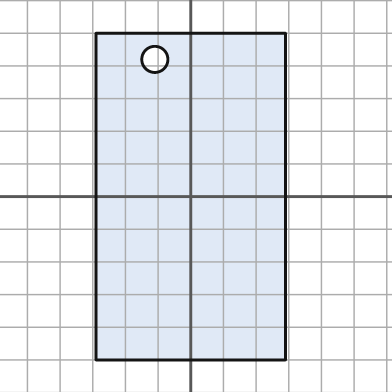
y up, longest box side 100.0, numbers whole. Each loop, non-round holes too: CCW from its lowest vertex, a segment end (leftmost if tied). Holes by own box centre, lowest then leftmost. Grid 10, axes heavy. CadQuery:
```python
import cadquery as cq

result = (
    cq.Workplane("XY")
    .moveTo(-29.0, -50.0)
    .lineTo(29.0, -50.0)
    .lineTo(29.0, 50.0)
    .lineTo(-29.0, 50.0)
    .close()
    .moveTo(-11.0, 42.0)
    .circle(4.0)
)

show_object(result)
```